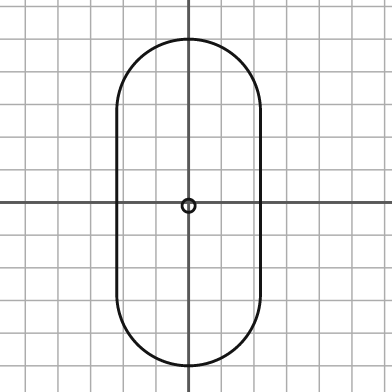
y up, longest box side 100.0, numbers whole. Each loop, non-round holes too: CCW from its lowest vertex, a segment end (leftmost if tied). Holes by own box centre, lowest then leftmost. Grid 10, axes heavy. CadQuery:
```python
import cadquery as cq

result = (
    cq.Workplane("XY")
    .moveTo(-22.0, -28.0)
    .threePointArc((0.0, -50.0), (22.0, -28.0))
    .lineTo(22.0, 28.0)
    .threePointArc((0.0, 50.0), (-22.0, 28.0))
    .close()
    .moveTo(0.0, -1.0)
    .circle(2.0)
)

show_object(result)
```